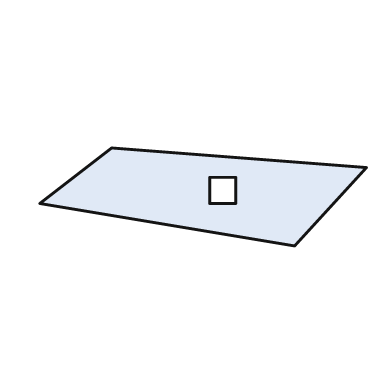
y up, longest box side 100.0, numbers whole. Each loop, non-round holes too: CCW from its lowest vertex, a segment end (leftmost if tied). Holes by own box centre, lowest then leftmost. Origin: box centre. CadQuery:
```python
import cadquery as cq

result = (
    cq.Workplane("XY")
    .moveTo(28.0, -15.0)
    .lineTo(50.0, 9.0)
    .lineTo(-28.0, 15.0)
    .lineTo(-50.0, -2.0)
    .close()
    .moveTo(2.0, -2.0)
    .lineTo(10.0, -2.0)
    .lineTo(10.0, 6.0)
    .lineTo(2.0, 6.0)
    .close()
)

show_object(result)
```